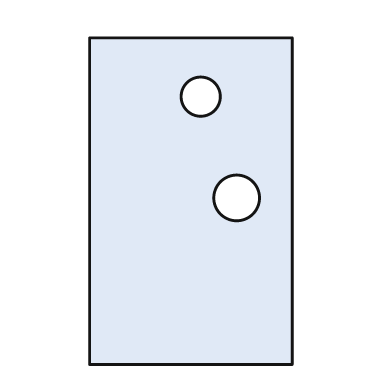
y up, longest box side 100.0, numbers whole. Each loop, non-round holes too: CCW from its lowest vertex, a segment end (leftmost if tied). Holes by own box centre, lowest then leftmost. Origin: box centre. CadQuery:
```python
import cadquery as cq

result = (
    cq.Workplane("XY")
    .moveTo(-31.0, -50.0)
    .lineTo(31.0, -50.0)
    .lineTo(31.0, 50.0)
    .lineTo(-31.0, 50.0)
    .close()
    .moveTo(14.0, 1.0)
    .circle(7.0)
    .moveTo(3.0, 32.0)
    .circle(6.0)
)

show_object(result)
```